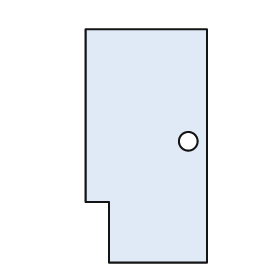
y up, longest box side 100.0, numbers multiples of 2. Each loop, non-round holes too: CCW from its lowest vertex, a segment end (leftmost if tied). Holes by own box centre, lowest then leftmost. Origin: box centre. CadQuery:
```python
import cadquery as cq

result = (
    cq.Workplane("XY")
    .moveTo(-16.0, -50.0)
    .lineTo(26.0, -50.0)
    .lineTo(26.0, 50.0)
    .lineTo(-26.0, 50.0)
    .lineTo(-26.0, -24.0)
    .lineTo(-16.0, -24.0)
    .close()
    .moveTo(18.0, 2.0)
    .circle(4.0)
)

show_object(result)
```